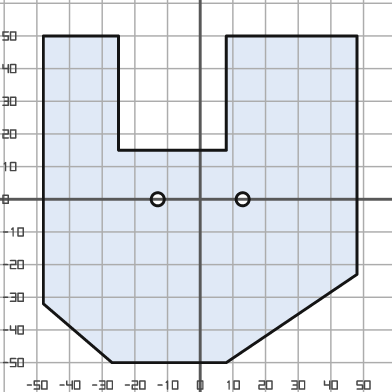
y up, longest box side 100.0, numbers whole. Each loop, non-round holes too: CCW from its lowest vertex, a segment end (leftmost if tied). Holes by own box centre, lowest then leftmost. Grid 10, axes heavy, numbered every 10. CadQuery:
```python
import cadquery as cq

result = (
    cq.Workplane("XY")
    .moveTo(-27.0, -50.0)
    .lineTo(8.0, -50.0)
    .lineTo(48.0, -23.0)
    .lineTo(48.0, 50.0)
    .lineTo(8.0, 50.0)
    .lineTo(8.0, 15.0)
    .lineTo(-25.0, 15.0)
    .lineTo(-25.0, 50.0)
    .lineTo(-48.0, 50.0)
    .lineTo(-48.0, -32.0)
    .close()
    .moveTo(-13.0, 0.0)
    .circle(2.0)
    .moveTo(13.0, 0.0)
    .circle(2.0)
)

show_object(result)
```